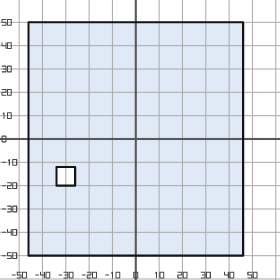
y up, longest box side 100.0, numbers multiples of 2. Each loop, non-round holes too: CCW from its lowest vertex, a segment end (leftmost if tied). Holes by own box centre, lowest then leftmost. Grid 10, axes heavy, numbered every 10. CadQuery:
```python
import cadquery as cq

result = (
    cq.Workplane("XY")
    .moveTo(-46.0, -50.0)
    .lineTo(46.0, -50.0)
    .lineTo(46.0, 50.0)
    .lineTo(-46.0, 50.0)
    .close()
    .moveTo(-34.0, -20.0)
    .lineTo(-26.0, -20.0)
    .lineTo(-26.0, -12.0)
    .lineTo(-34.0, -12.0)
    .close()
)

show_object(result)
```